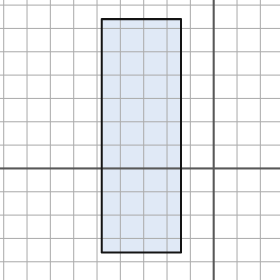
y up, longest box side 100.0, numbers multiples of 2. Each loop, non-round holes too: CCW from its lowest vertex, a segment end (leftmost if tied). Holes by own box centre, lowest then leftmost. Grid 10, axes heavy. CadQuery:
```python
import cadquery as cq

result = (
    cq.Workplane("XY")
    .moveTo(-48.0, -36.0)
    .lineTo(-14.0, -36.0)
    .lineTo(-14.0, 64.0)
    .lineTo(-48.0, 64.0)
    .close()
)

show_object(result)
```